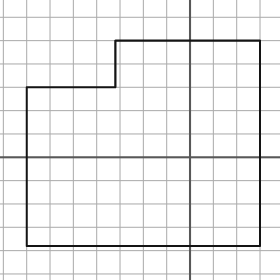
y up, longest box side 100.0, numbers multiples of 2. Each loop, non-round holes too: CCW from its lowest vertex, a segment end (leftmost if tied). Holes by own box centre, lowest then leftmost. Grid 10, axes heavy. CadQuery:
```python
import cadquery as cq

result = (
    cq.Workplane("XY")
    .moveTo(-70.0, -38.0)
    .lineTo(30.0, -38.0)
    .lineTo(30.0, 50.0)
    .lineTo(-32.0, 50.0)
    .lineTo(-32.0, 30.0)
    .lineTo(-70.0, 30.0)
    .close()
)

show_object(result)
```